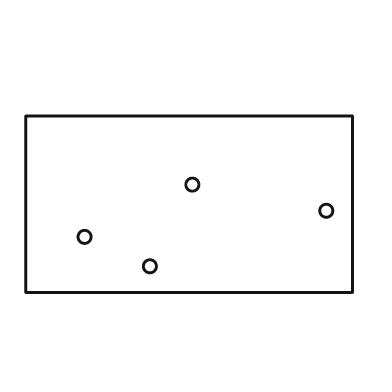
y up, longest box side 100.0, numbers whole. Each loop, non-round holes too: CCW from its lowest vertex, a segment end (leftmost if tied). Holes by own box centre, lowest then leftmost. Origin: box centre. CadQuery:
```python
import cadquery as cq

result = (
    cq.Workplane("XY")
    .moveTo(-50.0, -27.0)
    .lineTo(50.0, -27.0)
    .lineTo(50.0, 27.0)
    .lineTo(-50.0, 27.0)
    .close()
    .moveTo(-12.0, -19.0)
    .circle(2.0)
    .moveTo(-32.0, -10.0)
    .circle(2.0)
    .moveTo(42.0, -2.0)
    .circle(2.0)
    .moveTo(1.0, 6.0)
    .circle(2.0)
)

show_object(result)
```